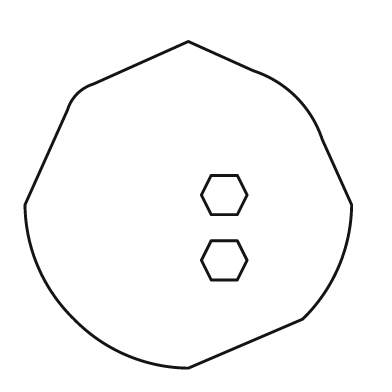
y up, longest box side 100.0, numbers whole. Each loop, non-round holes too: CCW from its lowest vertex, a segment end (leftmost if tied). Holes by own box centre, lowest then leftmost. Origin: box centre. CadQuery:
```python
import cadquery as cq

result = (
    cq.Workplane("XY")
    .moveTo(0.0, -50.0)
    .lineTo(35.0, -35.0)
    .threePointArc((46.0, -19.0), (50.0, 0.0))
    .lineTo(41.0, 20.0)
    .threePointArc((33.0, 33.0), (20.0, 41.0))
    .lineTo(0.0, 50.0)
    .lineTo(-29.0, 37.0)
    .threePointArc((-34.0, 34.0), (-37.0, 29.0))
    .lineTo(-50.0, 0.0)
    .threePointArc((-46.0, -19.0), (-35.0, -35.0))
    .threePointArc((-19.0, -46.0), (0.0, -50.0))
    .close()
    .moveTo(7.0, -23.0)
    .lineTo(15.0, -23.0)
    .lineTo(18.0, -17.0)
    .lineTo(15.0, -11.0)
    .lineTo(7.0, -11.0)
    .lineTo(4.0, -17.0)
    .close()
    .moveTo(7.0, -3.0)
    .lineTo(15.0, -3.0)
    .lineTo(18.0, 3.0)
    .lineTo(15.0, 9.0)
    .lineTo(7.0, 9.0)
    .lineTo(4.0, 3.0)
    .close()
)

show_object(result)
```